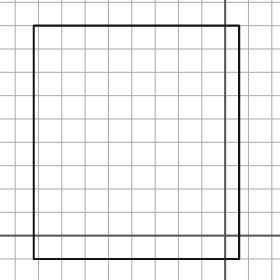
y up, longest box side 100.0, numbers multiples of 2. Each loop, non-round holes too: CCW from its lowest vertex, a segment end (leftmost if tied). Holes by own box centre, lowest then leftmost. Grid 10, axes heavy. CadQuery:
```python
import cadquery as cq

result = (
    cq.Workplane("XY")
    .moveTo(-82.0, -10.0)
    .lineTo(6.0, -10.0)
    .lineTo(6.0, 90.0)
    .lineTo(-82.0, 90.0)
    .close()
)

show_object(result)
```